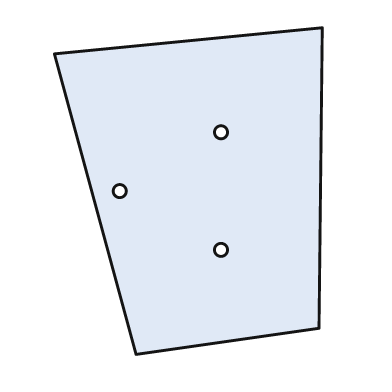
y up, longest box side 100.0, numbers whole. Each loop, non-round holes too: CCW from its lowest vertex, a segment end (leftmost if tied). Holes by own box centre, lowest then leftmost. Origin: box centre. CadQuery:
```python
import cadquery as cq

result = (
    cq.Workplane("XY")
    .moveTo(-16.0, -50.0)
    .lineTo(40.0, -42.0)
    .lineTo(41.0, 50.0)
    .lineTo(-41.0, 42.0)
    .close()
    .moveTo(10.0, -18.0)
    .circle(2.0)
    .moveTo(-21.0, 0.0)
    .circle(2.0)
    .moveTo(10.0, 18.0)
    .circle(2.0)
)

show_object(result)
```